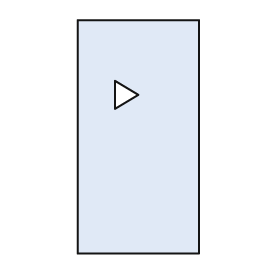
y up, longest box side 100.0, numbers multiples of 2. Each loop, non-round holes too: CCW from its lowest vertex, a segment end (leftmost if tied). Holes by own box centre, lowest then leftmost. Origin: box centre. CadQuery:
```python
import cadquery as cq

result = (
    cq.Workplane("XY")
    .moveTo(-26.0, -50.0)
    .lineTo(26.0, -50.0)
    .lineTo(26.0, 50.0)
    .lineTo(-26.0, 50.0)
    .close()
    .moveTo(-10.0, 12.0)
    .lineTo(0.0, 18.0)
    .lineTo(-10.0, 24.0)
    .close()
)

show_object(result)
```